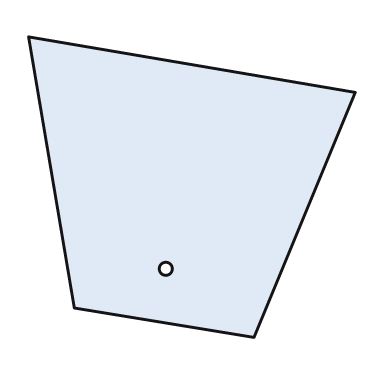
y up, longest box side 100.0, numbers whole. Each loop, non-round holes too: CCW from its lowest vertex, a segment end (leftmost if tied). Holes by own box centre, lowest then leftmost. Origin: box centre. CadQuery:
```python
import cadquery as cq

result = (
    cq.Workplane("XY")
    .moveTo(19.0, -46.0)
    .lineTo(50.0, 29.0)
    .lineTo(-50.0, 46.0)
    .lineTo(-36.0, -37.0)
    .close()
    .moveTo(-8.0, -25.0)
    .circle(2.0)
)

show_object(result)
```